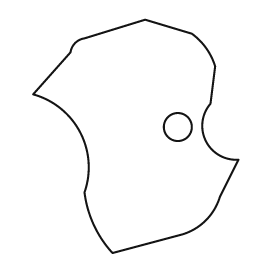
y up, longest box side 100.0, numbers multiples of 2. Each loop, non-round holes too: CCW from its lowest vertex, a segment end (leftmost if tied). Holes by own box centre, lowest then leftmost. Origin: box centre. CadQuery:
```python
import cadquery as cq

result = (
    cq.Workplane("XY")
    .moveTo(-10.0, -50.0)
    .lineTo(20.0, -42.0)
    .threePointArc((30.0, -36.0), (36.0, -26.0))
    .lineTo(44.0, -10.0)
    .threePointArc((30.0, -2.0), (32.0, 14.0))
    .lineTo(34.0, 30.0)
    .threePointArc((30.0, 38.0), (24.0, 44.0))
    .lineTo(4.0, 50.0)
    .lineTo(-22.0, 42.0)
    .threePointArc((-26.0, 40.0), (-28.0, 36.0))
    .lineTo(-44.0, 18.0)
    .threePointArc((-24.0, 2.0), (-22.0, -24.0))
    .threePointArc((-18.0, -38.0), (-10.0, -50.0))
    .close()
    .moveTo(18.0, 4.0)
    .circle(6.0)
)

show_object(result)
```